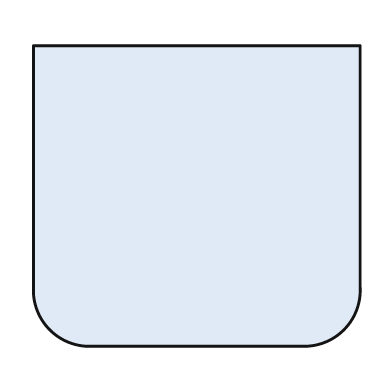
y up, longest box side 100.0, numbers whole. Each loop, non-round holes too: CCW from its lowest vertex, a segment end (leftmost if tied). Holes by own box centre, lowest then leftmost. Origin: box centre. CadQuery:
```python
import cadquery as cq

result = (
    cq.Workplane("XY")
    .moveTo(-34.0, -46.0)
    .lineTo(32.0, -46.0)
    .threePointArc((45.0, -41.0), (50.0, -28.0))
    .lineTo(50.0, 46.0)
    .lineTo(-50.0, 46.0)
    .lineTo(-50.0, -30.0)
    .threePointArc((-45.0, -41.0), (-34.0, -46.0))
    .close()
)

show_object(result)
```